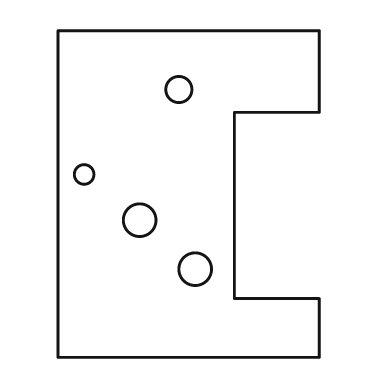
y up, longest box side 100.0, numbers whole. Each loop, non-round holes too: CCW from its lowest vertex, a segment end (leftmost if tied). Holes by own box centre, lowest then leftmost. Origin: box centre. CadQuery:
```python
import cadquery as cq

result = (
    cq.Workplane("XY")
    .moveTo(-40.0, -50.0)
    .lineTo(40.0, -50.0)
    .lineTo(40.0, -32.0)
    .lineTo(14.0, -32.0)
    .lineTo(14.0, 25.0)
    .lineTo(40.0, 25.0)
    .lineTo(40.0, 50.0)
    .lineTo(-40.0, 50.0)
    .close()
    .moveTo(2.0, -23.0)
    .circle(5.0)
    .moveTo(-15.0, -8.0)
    .circle(5.0)
    .moveTo(-32.0, 6.0)
    .circle(3.0)
    .moveTo(-3.0, 32.0)
    .circle(4.0)
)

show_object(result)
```